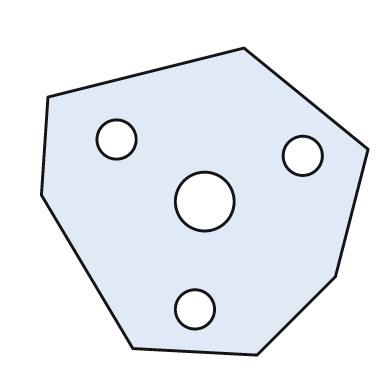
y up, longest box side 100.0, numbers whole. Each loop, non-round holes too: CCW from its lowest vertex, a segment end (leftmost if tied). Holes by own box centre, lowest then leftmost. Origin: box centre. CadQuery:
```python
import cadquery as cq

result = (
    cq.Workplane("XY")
    .moveTo(16.0, -47.0)
    .lineTo(40.0, -23.0)
    .lineTo(50.0, 16.0)
    .lineTo(12.0, 47.0)
    .lineTo(-48.0, 32.0)
    .lineTo(-50.0, 2.0)
    .lineTo(-22.0, -45.0)
    .close()
    .moveTo(-3.0, -33.0)
    .circle(6.0)
    .moveTo(0.0, 0.0)
    .circle(9.0)
    .moveTo(30.0, 14.0)
    .circle(6.0)
    .moveTo(-27.0, 19.0)
    .circle(6.0)
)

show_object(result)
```